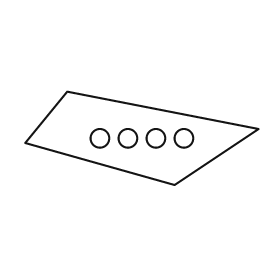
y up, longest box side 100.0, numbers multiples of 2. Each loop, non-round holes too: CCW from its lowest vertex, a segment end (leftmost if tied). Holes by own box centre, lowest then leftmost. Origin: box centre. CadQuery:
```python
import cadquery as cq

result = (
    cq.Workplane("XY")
    .moveTo(14.0, -20.0)
    .lineTo(50.0, 4.0)
    .lineTo(-32.0, 20.0)
    .lineTo(-50.0, -2.0)
    .close()
    .moveTo(-18.0, 0.0)
    .circle(4.0)
    .moveTo(-6.0, 0.0)
    .circle(4.0)
    .moveTo(6.0, 0.0)
    .circle(4.0)
    .moveTo(18.0, 0.0)
    .circle(4.0)
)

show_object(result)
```